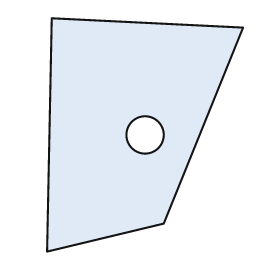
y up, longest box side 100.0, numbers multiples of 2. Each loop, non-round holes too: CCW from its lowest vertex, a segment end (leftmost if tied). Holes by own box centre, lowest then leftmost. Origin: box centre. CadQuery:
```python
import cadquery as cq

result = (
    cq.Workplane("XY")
    .moveTo(-42.0, -50.0)
    .lineTo(8.0, -38.0)
    .lineTo(42.0, 46.0)
    .lineTo(-40.0, 50.0)
    .close()
    .moveTo(0.0, 0.0)
    .circle(8.0)
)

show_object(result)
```